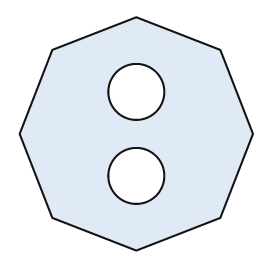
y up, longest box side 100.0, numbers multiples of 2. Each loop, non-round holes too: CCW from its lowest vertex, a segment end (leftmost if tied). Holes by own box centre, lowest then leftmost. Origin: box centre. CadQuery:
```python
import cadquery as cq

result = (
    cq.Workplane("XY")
    .moveTo(0.0, -50.0)
    .lineTo(36.0, -36.0)
    .lineTo(50.0, 0.0)
    .lineTo(36.0, 36.0)
    .lineTo(0.0, 50.0)
    .lineTo(-36.0, 36.0)
    .lineTo(-50.0, 0.0)
    .lineTo(-36.0, -36.0)
    .close()
    .moveTo(0.0, -18.0)
    .circle(12.0)
    .moveTo(0.0, 18.0)
    .circle(12.0)
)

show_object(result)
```